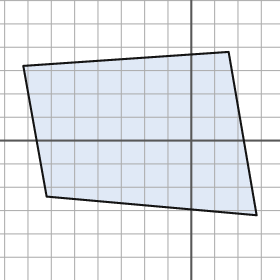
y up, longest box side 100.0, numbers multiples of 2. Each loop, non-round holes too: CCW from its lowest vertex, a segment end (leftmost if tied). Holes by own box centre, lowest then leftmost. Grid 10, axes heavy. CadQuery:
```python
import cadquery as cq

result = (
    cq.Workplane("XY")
    .moveTo(28.0, -32.0)
    .lineTo(16.0, 38.0)
    .lineTo(-72.0, 32.0)
    .lineTo(-62.0, -24.0)
    .close()
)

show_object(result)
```